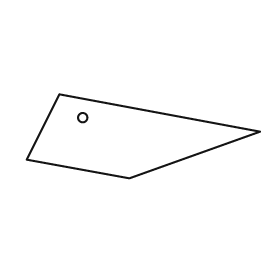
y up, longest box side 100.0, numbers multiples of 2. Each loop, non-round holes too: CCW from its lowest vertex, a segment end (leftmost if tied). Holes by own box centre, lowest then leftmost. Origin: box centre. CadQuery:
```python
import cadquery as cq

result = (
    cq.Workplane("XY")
    .moveTo(-6.0, -18.0)
    .lineTo(50.0, 2.0)
    .lineTo(-36.0, 18.0)
    .lineTo(-50.0, -10.0)
    .close()
    .moveTo(-26.0, 8.0)
    .circle(2.0)
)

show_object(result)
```